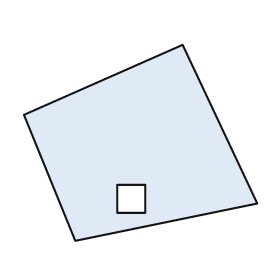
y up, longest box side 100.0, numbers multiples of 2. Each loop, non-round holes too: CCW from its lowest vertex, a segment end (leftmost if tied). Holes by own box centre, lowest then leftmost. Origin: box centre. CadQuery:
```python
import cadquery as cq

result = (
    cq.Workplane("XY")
    .moveTo(-28.0, -42.0)
    .lineTo(50.0, -26.0)
    .lineTo(18.0, 42.0)
    .lineTo(-50.0, 12.0)
    .close()
    .moveTo(-10.0, -30.0)
    .lineTo(2.0, -30.0)
    .lineTo(2.0, -18.0)
    .lineTo(-10.0, -18.0)
    .close()
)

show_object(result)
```